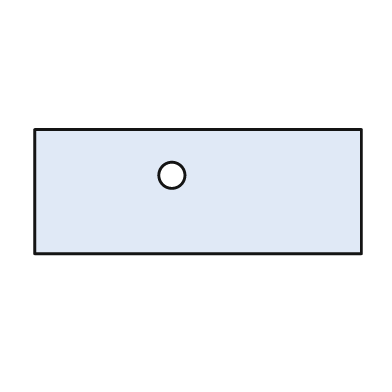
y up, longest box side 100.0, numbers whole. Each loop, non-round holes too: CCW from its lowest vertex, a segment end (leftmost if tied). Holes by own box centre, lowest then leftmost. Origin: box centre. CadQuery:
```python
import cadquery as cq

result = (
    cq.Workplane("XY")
    .moveTo(-50.0, -19.0)
    .lineTo(50.0, -19.0)
    .lineTo(50.0, 19.0)
    .lineTo(-50.0, 19.0)
    .close()
    .moveTo(-8.0, 5.0)
    .circle(4.0)
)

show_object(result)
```